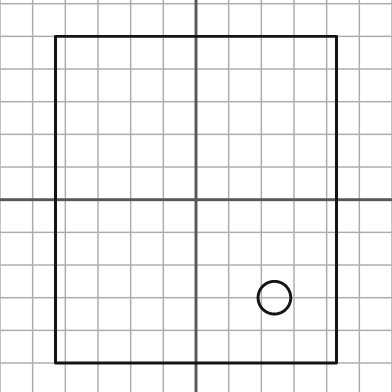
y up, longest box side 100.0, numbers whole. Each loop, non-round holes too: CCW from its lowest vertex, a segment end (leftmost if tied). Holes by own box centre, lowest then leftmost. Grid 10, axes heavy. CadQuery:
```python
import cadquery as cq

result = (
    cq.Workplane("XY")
    .moveTo(-43.0, -50.0)
    .lineTo(43.0, -50.0)
    .lineTo(43.0, 50.0)
    .lineTo(-43.0, 50.0)
    .close()
    .moveTo(24.0, -30.0)
    .circle(5.0)
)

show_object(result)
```